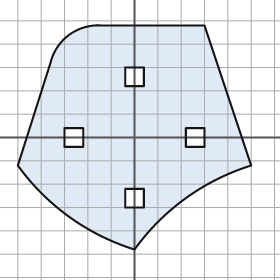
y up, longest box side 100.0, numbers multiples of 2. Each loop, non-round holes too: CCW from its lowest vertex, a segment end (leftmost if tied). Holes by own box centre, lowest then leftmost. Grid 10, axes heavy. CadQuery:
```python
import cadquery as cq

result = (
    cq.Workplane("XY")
    .moveTo(0.0, -48.0)
    .threePointArc((22.0, -26.0), (50.0, -12.0))
    .lineTo(30.0, 48.0)
    .lineTo(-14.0, 48.0)
    .threePointArc((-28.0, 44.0), (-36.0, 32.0))
    .lineTo(-50.0, -12.0)
    .threePointArc((-28.0, -34.0), (0.0, -48.0))
    .close()
    .moveTo(-4.0, -30.0)
    .lineTo(4.0, -30.0)
    .lineTo(4.0, -22.0)
    .lineTo(-4.0, -22.0)
    .close()
    .moveTo(-30.0, -4.0)
    .lineTo(-22.0, -4.0)
    .lineTo(-22.0, 4.0)
    .lineTo(-30.0, 4.0)
    .close()
    .moveTo(22.0, -4.0)
    .lineTo(30.0, -4.0)
    .lineTo(30.0, 4.0)
    .lineTo(22.0, 4.0)
    .close()
    .moveTo(-4.0, 22.0)
    .lineTo(4.0, 22.0)
    .lineTo(4.0, 30.0)
    .lineTo(-4.0, 30.0)
    .close()
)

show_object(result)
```